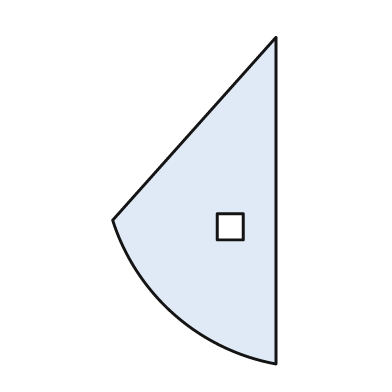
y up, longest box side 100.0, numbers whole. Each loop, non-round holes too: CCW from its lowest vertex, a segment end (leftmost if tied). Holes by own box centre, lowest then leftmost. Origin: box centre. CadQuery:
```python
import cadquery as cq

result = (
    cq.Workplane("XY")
    .moveTo(25.0, -50.0)
    .lineTo(25.0, 50.0)
    .lineTo(-25.0, -6.0)
    .threePointArc((-6.0, -35.0), (25.0, -50.0))
    .close()
    .moveTo(7.0, -12.0)
    .lineTo(15.0, -12.0)
    .lineTo(15.0, -4.0)
    .lineTo(7.0, -4.0)
    .close()
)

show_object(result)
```